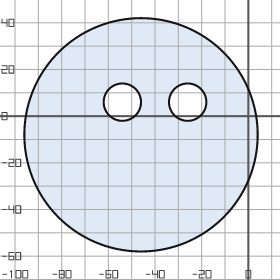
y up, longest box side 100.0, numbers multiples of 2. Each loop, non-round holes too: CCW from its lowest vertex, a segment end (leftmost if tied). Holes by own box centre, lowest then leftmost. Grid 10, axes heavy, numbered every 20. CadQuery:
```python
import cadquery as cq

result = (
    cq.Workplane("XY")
    .moveTo(-46.0, -8.0)
    .circle(50.0)
    .moveTo(-54.0, 6.0)
    .circle(8.0)
    .moveTo(-26.0, 6.0)
    .circle(8.0)
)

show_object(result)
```